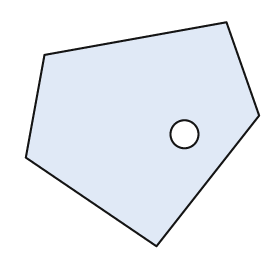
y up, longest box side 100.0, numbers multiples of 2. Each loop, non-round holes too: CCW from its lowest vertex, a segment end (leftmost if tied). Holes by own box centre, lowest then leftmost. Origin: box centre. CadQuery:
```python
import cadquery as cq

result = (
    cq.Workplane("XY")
    .moveTo(6.0, -48.0)
    .lineTo(50.0, 8.0)
    .lineTo(36.0, 48.0)
    .lineTo(-42.0, 34.0)
    .lineTo(-50.0, -10.0)
    .close()
    .moveTo(18.0, 0.0)
    .circle(6.0)
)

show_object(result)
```